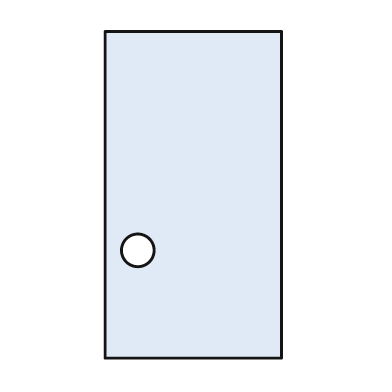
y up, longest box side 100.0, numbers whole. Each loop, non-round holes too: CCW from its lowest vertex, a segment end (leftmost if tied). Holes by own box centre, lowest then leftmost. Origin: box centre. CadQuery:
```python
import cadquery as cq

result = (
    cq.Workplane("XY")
    .moveTo(-27.0, -50.0)
    .lineTo(27.0, -50.0)
    .lineTo(27.0, 50.0)
    .lineTo(-27.0, 50.0)
    .close()
    .moveTo(-17.0, -17.0)
    .circle(5.0)
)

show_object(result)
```